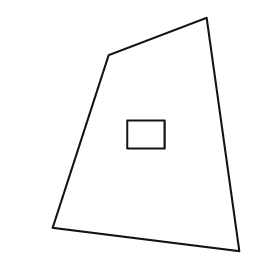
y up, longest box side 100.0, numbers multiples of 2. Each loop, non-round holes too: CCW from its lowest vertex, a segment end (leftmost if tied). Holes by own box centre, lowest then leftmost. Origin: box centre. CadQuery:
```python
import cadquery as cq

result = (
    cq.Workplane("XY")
    .moveTo(40.0, -50.0)
    .lineTo(26.0, 50.0)
    .lineTo(-16.0, 34.0)
    .lineTo(-40.0, -40.0)
    .close()
    .moveTo(-8.0, -6.0)
    .lineTo(8.0, -6.0)
    .lineTo(8.0, 6.0)
    .lineTo(-8.0, 6.0)
    .close()
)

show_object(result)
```